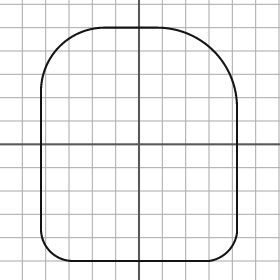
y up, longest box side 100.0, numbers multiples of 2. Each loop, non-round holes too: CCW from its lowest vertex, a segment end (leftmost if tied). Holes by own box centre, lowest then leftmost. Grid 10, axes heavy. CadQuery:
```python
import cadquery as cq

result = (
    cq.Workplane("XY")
    .moveTo(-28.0, -50.0)
    .lineTo(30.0, -50.0)
    .threePointArc((38.0, -46.0), (42.0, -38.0))
    .lineTo(42.0, 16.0)
    .threePointArc((32.0, 40.0), (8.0, 50.0))
    .lineTo(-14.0, 50.0)
    .threePointArc((-34.0, 42.0), (-42.0, 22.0))
    .lineTo(-42.0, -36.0)
    .threePointArc((-38.0, -46.0), (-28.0, -50.0))
    .close()
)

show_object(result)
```